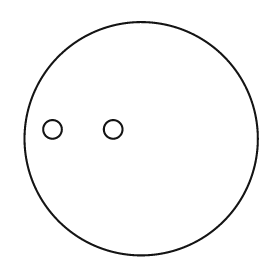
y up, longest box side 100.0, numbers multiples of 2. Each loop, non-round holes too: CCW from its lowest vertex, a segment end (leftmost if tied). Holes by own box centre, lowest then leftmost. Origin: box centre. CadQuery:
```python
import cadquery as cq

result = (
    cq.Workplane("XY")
    .moveTo(0.0, 0.0)
    .circle(50.0)
    .moveTo(-38.0, 4.0)
    .circle(4.0)
    .moveTo(-12.0, 4.0)
    .circle(4.0)
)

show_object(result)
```